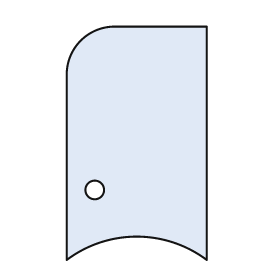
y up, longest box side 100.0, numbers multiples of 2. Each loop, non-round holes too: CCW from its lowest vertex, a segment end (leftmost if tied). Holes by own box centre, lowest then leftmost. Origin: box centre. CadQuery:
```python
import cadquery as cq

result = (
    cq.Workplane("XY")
    .moveTo(-30.0, -50.0)
    .threePointArc((0.0, -40.0), (30.0, -50.0))
    .lineTo(30.0, 50.0)
    .lineTo(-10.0, 50.0)
    .threePointArc((-24.0, 44.0), (-30.0, 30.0))
    .close()
    .moveTo(-18.0, -20.0)
    .circle(4.0)
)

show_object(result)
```